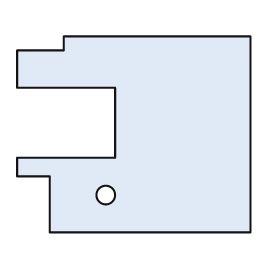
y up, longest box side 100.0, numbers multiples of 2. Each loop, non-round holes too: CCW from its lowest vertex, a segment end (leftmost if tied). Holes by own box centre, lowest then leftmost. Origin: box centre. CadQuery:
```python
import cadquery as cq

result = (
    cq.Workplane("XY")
    .moveTo(-36.0, -42.0)
    .lineTo(50.0, -42.0)
    .lineTo(50.0, 42.0)
    .lineTo(-30.0, 42.0)
    .lineTo(-30.0, 36.0)
    .lineTo(-50.0, 36.0)
    .lineTo(-50.0, 20.0)
    .lineTo(-8.0, 20.0)
    .lineTo(-8.0, -10.0)
    .lineTo(-50.0, -10.0)
    .lineTo(-50.0, -18.0)
    .lineTo(-36.0, -18.0)
    .close()
    .moveTo(-12.0, -26.0)
    .circle(4.0)
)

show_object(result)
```